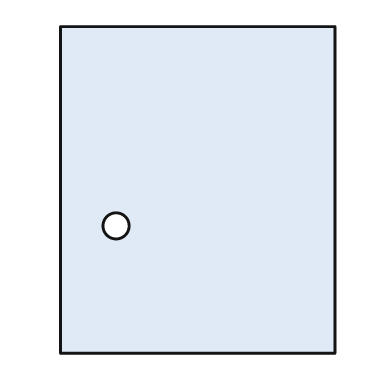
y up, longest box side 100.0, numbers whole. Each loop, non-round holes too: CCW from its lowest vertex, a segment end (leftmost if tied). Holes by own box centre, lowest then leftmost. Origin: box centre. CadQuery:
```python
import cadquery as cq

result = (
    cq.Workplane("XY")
    .moveTo(-42.0, -50.0)
    .lineTo(42.0, -50.0)
    .lineTo(42.0, 50.0)
    .lineTo(-42.0, 50.0)
    .close()
    .moveTo(-25.0, -11.0)
    .circle(4.0)
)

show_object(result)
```